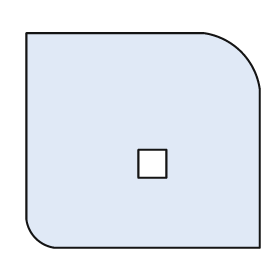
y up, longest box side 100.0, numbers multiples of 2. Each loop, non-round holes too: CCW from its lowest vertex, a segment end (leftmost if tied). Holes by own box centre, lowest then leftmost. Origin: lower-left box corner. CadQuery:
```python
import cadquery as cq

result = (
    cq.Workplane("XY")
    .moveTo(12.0, 0.0)
    .lineTo(100.0, 0.0)
    .lineTo(100.0, 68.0)
    .threePointArc((92.0, 84.0), (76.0, 92.0))
    .lineTo(0.0, 92.0)
    .lineTo(0.0, 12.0)
    .threePointArc((4.0, 4.0), (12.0, 0.0))
    .close()
    .moveTo(48.0, 30.0)
    .lineTo(60.0, 30.0)
    .lineTo(60.0, 42.0)
    .lineTo(48.0, 42.0)
    .close()
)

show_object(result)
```